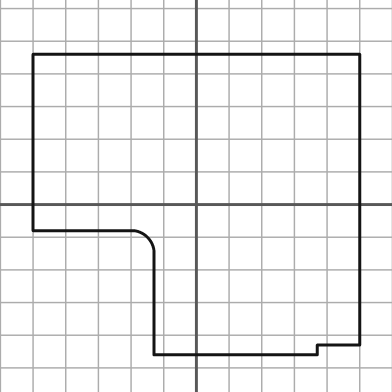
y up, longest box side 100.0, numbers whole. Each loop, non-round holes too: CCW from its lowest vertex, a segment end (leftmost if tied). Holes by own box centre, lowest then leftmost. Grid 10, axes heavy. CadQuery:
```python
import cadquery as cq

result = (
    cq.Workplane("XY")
    .moveTo(-13.0, -46.0)
    .lineTo(37.0, -46.0)
    .lineTo(37.0, -43.0)
    .lineTo(50.0, -43.0)
    .lineTo(50.0, 46.0)
    .lineTo(-50.0, 46.0)
    .lineTo(-50.0, -8.0)
    .lineTo(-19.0, -8.0)
    .threePointArc((-15.0, -10.0), (-13.0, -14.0))
    .close()
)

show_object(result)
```